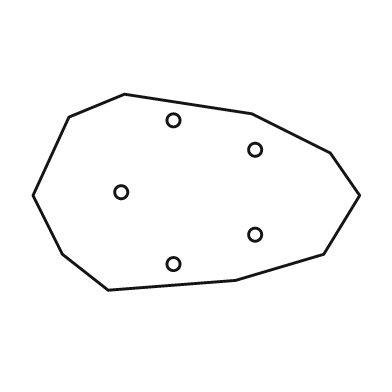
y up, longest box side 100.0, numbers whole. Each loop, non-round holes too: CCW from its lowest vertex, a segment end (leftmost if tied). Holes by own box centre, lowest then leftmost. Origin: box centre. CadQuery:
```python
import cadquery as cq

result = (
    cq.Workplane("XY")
    .moveTo(-27.0, -30.0)
    .lineTo(12.0, -27.0)
    .lineTo(39.0, -19.0)
    .lineTo(50.0, -1.0)
    .lineTo(41.0, 12.0)
    .lineTo(17.0, 24.0)
    .lineTo(-22.0, 30.0)
    .lineTo(-39.0, 23.0)
    .lineTo(-50.0, -1.0)
    .lineTo(-41.0, -19.0)
    .close()
    .moveTo(-7.0, -22.0)
    .circle(2.0)
    .moveTo(18.0, -13.0)
    .circle(2.0)
    .moveTo(-23.0, 0.0)
    .circle(2.0)
    .moveTo(18.0, 13.0)
    .circle(2.0)
    .moveTo(-7.0, 22.0)
    .circle(2.0)
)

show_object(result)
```